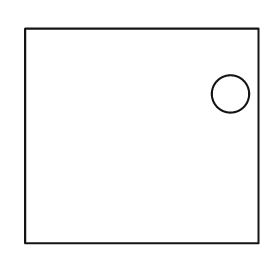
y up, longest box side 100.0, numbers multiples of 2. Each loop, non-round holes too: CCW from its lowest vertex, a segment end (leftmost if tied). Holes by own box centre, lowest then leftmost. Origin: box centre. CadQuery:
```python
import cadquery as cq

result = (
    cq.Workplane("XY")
    .moveTo(-50.0, -46.0)
    .lineTo(50.0, -46.0)
    .lineTo(50.0, 46.0)
    .lineTo(-50.0, 46.0)
    .close()
    .moveTo(38.0, 18.0)
    .circle(8.0)
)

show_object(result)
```